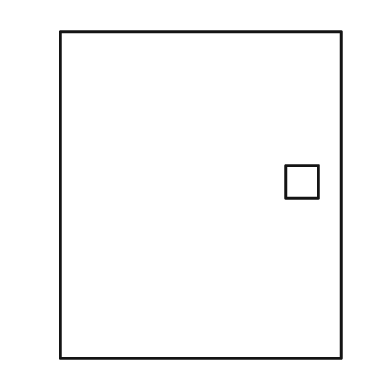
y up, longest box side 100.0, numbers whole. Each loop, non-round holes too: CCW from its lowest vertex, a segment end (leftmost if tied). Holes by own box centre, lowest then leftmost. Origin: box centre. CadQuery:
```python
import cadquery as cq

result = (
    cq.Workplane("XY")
    .moveTo(-43.0, -50.0)
    .lineTo(43.0, -50.0)
    .lineTo(43.0, 50.0)
    .lineTo(-43.0, 50.0)
    .close()
    .moveTo(26.0, -1.0)
    .lineTo(36.0, -1.0)
    .lineTo(36.0, 9.0)
    .lineTo(26.0, 9.0)
    .close()
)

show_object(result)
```